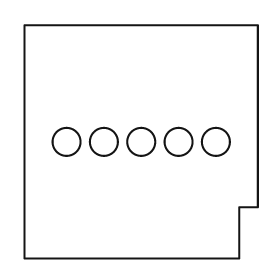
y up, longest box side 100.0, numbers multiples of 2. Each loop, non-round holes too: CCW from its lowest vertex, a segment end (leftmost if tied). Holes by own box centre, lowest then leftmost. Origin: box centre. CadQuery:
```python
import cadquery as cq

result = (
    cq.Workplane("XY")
    .moveTo(-50.0, -50.0)
    .lineTo(42.0, -50.0)
    .lineTo(42.0, -28.0)
    .lineTo(50.0, -28.0)
    .lineTo(50.0, 50.0)
    .lineTo(-50.0, 50.0)
    .close()
    .moveTo(-32.0, 0.0)
    .circle(6.0)
    .moveTo(-16.0, 0.0)
    .circle(6.0)
    .moveTo(0.0, 0.0)
    .circle(6.0)
    .moveTo(16.0, 0.0)
    .circle(6.0)
    .moveTo(32.0, 0.0)
    .circle(6.0)
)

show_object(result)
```